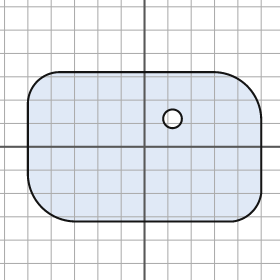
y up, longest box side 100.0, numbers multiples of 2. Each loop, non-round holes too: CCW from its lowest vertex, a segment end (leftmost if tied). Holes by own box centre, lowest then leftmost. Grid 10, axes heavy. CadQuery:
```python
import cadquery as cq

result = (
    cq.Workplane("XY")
    .moveTo(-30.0, -32.0)
    .lineTo(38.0, -32.0)
    .threePointArc((46.0, -28.0), (50.0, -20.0))
    .lineTo(50.0, 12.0)
    .threePointArc((44.0, 26.0), (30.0, 32.0))
    .lineTo(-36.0, 32.0)
    .threePointArc((-46.0, 28.0), (-50.0, 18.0))
    .lineTo(-50.0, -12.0)
    .threePointArc((-44.0, -26.0), (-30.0, -32.0))
    .close()
    .moveTo(12.0, 12.0)
    .circle(4.0)
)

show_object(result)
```